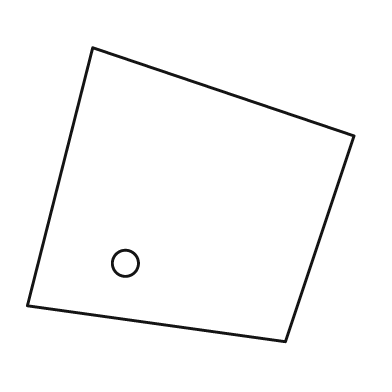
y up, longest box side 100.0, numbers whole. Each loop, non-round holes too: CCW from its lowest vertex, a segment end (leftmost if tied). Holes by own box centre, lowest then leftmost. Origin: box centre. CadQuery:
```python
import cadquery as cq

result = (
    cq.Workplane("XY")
    .moveTo(29.0, -45.0)
    .lineTo(50.0, 18.0)
    .lineTo(-30.0, 45.0)
    .lineTo(-50.0, -34.0)
    .close()
    .moveTo(-20.0, -21.0)
    .circle(4.0)
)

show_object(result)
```